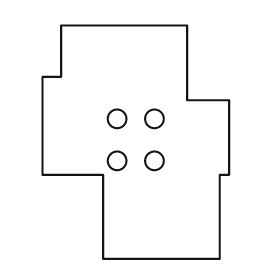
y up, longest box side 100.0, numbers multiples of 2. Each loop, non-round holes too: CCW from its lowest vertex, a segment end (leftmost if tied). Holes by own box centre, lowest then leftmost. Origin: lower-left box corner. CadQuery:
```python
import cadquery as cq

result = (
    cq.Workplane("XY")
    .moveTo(26.0, 0.0)
    .lineTo(76.0, 0.0)
    .lineTo(76.0, 36.0)
    .lineTo(80.0, 36.0)
    .lineTo(80.0, 68.0)
    .lineTo(62.0, 68.0)
    .lineTo(62.0, 100.0)
    .lineTo(8.0, 100.0)
    .lineTo(8.0, 78.0)
    .lineTo(0.0, 78.0)
    .lineTo(0.0, 36.0)
    .lineTo(26.0, 36.0)
    .close()
    .moveTo(32.0, 42.0)
    .circle(4.0)
    .moveTo(48.0, 42.0)
    .circle(4.0)
    .moveTo(32.0, 60.0)
    .circle(4.0)
    .moveTo(48.0, 60.0)
    .circle(4.0)
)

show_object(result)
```